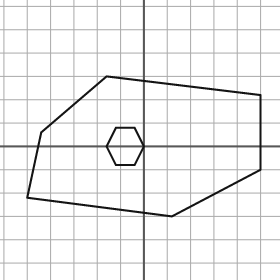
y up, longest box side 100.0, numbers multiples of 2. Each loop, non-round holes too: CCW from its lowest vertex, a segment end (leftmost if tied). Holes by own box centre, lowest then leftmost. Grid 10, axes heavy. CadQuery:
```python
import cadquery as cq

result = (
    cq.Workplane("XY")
    .moveTo(12.0, -30.0)
    .lineTo(50.0, -10.0)
    .lineTo(50.0, 22.0)
    .lineTo(-16.0, 30.0)
    .lineTo(-44.0, 6.0)
    .lineTo(-50.0, -22.0)
    .close()
    .moveTo(-12.0, -8.0)
    .lineTo(-4.0, -8.0)
    .lineTo(0.0, 0.0)
    .lineTo(-4.0, 8.0)
    .lineTo(-12.0, 8.0)
    .lineTo(-16.0, 0.0)
    .close()
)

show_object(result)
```